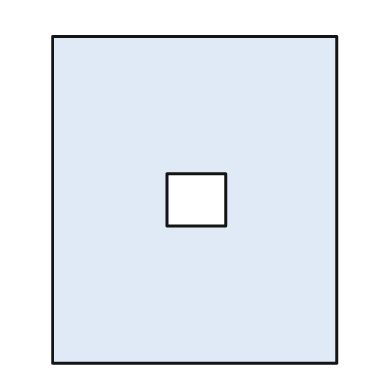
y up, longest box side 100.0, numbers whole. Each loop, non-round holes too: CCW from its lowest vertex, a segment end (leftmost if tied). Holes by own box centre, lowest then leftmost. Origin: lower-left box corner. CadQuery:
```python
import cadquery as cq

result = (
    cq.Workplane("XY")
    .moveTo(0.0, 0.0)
    .lineTo(87.0, 0.0)
    .lineTo(87.0, 100.0)
    .lineTo(0.0, 100.0)
    .close()
    .moveTo(35.0, 42.0)
    .lineTo(53.0, 42.0)
    .lineTo(53.0, 58.0)
    .lineTo(35.0, 58.0)
    .close()
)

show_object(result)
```